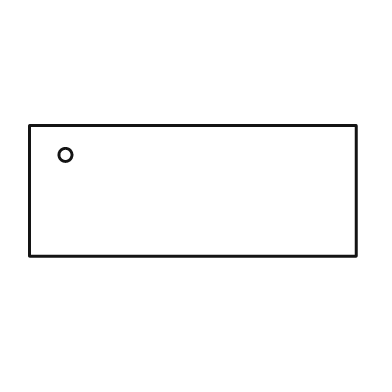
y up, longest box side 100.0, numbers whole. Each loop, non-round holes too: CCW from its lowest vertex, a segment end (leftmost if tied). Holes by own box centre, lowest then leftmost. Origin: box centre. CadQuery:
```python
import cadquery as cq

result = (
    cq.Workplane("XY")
    .moveTo(-50.0, -20.0)
    .lineTo(50.0, -20.0)
    .lineTo(50.0, 20.0)
    .lineTo(-50.0, 20.0)
    .close()
    .moveTo(-39.0, 11.0)
    .circle(2.0)
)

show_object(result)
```